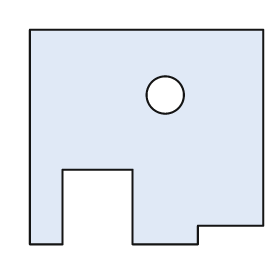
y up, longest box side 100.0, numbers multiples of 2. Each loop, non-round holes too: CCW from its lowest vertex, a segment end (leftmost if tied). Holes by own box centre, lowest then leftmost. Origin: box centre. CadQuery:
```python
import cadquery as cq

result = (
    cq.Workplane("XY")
    .moveTo(-50.0, -46.0)
    .lineTo(-36.0, -46.0)
    .lineTo(-36.0, -14.0)
    .lineTo(-6.0, -14.0)
    .lineTo(-6.0, -46.0)
    .lineTo(22.0, -46.0)
    .lineTo(22.0, -38.0)
    .lineTo(50.0, -38.0)
    .lineTo(50.0, 46.0)
    .lineTo(-50.0, 46.0)
    .close()
    .moveTo(8.0, 18.0)
    .circle(8.0)
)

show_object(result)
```